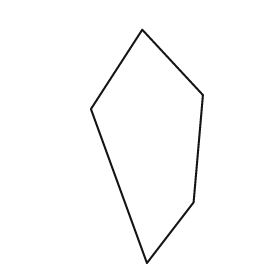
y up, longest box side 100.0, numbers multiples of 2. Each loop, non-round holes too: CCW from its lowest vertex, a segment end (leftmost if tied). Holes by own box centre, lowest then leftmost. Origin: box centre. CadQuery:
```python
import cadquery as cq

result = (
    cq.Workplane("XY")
    .moveTo(0.0, -50.0)
    .lineTo(20.0, -24.0)
    .lineTo(24.0, 22.0)
    .lineTo(-2.0, 50.0)
    .lineTo(-24.0, 16.0)
    .close()
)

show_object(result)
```